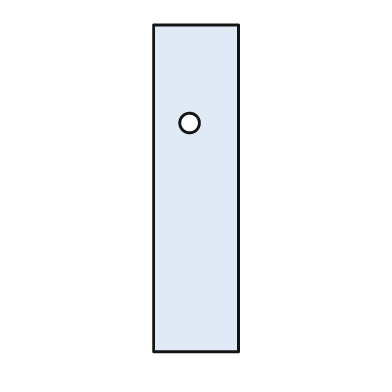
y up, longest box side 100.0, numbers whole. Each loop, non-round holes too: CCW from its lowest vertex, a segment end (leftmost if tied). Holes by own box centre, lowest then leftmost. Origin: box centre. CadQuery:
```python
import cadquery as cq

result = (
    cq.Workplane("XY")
    .moveTo(-13.0, -50.0)
    .lineTo(13.0, -50.0)
    .lineTo(13.0, 50.0)
    .lineTo(-13.0, 50.0)
    .close()
    .moveTo(-2.0, 20.0)
    .circle(3.0)
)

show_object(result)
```